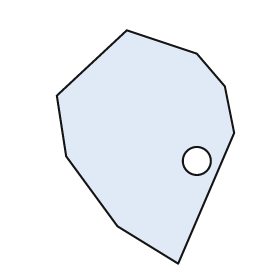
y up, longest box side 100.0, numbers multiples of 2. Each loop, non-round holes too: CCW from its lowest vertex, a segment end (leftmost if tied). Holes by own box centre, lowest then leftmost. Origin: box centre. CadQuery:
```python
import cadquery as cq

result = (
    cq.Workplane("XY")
    .moveTo(14.0, -50.0)
    .lineTo(38.0, 6.0)
    .lineTo(34.0, 26.0)
    .lineTo(22.0, 40.0)
    .lineTo(-8.0, 50.0)
    .lineTo(-38.0, 22.0)
    .lineTo(-34.0, -4.0)
    .lineTo(-12.0, -34.0)
    .close()
    .moveTo(22.0, -6.0)
    .circle(6.0)
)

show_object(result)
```